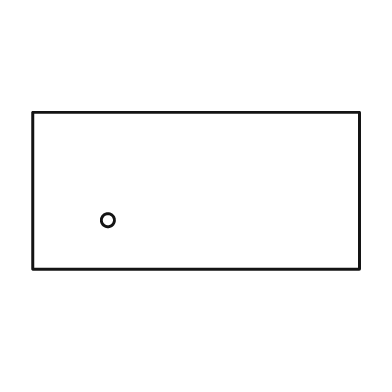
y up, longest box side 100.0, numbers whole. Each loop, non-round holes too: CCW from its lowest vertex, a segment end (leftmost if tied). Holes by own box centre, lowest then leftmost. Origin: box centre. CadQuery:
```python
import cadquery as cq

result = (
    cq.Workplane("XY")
    .moveTo(-50.0, -24.0)
    .lineTo(50.0, -24.0)
    .lineTo(50.0, 24.0)
    .lineTo(-50.0, 24.0)
    .close()
    .moveTo(-27.0, -9.0)
    .circle(2.0)
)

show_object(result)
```